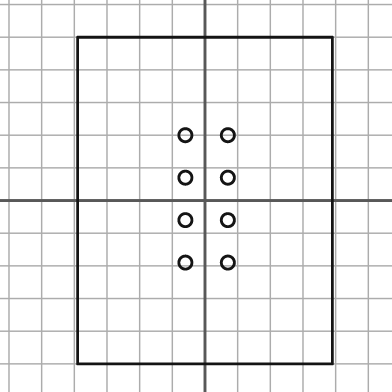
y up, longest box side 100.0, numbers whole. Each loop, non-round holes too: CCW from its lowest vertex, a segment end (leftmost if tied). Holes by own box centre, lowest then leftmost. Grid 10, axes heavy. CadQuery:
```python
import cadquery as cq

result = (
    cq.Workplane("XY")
    .moveTo(-39.0, -50.0)
    .lineTo(39.0, -50.0)
    .lineTo(39.0, 50.0)
    .lineTo(-39.0, 50.0)
    .close()
    .moveTo(-6.0, -19.0)
    .circle(2.0)
    .moveTo(7.0, -19.0)
    .circle(2.0)
    .moveTo(-6.0, -6.0)
    .circle(2.0)
    .moveTo(7.0, -6.0)
    .circle(2.0)
    .moveTo(-6.0, 7.0)
    .circle(2.0)
    .moveTo(7.0, 7.0)
    .circle(2.0)
    .moveTo(-6.0, 20.0)
    .circle(2.0)
    .moveTo(7.0, 20.0)
    .circle(2.0)
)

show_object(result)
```